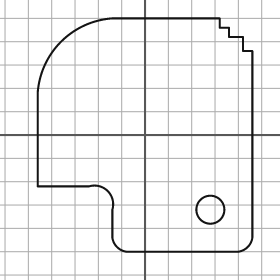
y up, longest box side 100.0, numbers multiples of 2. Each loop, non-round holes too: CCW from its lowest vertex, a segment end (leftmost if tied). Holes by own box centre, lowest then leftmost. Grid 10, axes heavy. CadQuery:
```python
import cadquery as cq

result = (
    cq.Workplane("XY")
    .moveTo(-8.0, -50.0)
    .lineTo(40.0, -50.0)
    .threePointArc((44.0, -48.0), (46.0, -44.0))
    .lineTo(46.0, 36.0)
    .lineTo(42.0, 36.0)
    .lineTo(42.0, 42.0)
    .lineTo(36.0, 42.0)
    .lineTo(36.0, 46.0)
    .lineTo(32.0, 46.0)
    .lineTo(32.0, 50.0)
    .lineTo(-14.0, 50.0)
    .threePointArc((-36.0, 40.0), (-46.0, 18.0))
    .lineTo(-46.0, -22.0)
    .lineTo(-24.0, -22.0)
    .threePointArc((-16.0, -24.0), (-14.0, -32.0))
    .lineTo(-14.0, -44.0)
    .threePointArc((-12.0, -48.0), (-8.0, -50.0))
    .close()
    .moveTo(28.0, -32.0)
    .circle(6.0)
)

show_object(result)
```